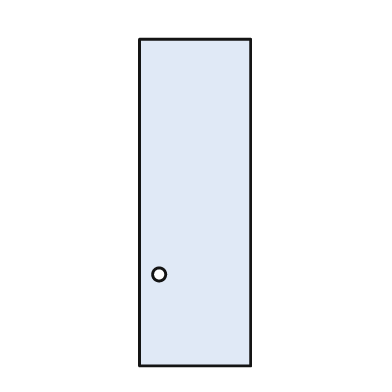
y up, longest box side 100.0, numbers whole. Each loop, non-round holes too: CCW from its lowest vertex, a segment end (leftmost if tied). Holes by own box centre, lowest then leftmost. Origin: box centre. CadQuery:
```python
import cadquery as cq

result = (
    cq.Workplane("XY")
    .moveTo(-17.0, -50.0)
    .lineTo(17.0, -50.0)
    .lineTo(17.0, 50.0)
    .lineTo(-17.0, 50.0)
    .close()
    .moveTo(-11.0, -22.0)
    .circle(2.0)
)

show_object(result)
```